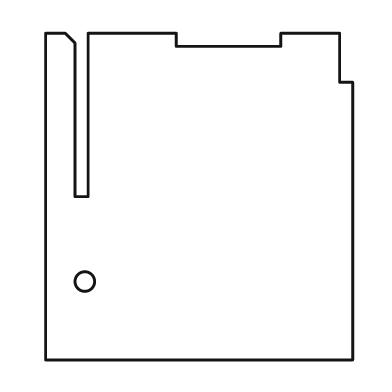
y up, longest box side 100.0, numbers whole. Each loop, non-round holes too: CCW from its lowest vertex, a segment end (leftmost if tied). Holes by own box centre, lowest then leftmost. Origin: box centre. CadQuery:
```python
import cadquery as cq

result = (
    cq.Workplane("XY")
    .moveTo(-47.0, -50.0)
    .lineTo(47.0, -50.0)
    .lineTo(47.0, 35.0)
    .lineTo(43.0, 35.0)
    .lineTo(43.0, 50.0)
    .lineTo(25.0, 50.0)
    .lineTo(25.0, 46.0)
    .lineTo(-7.0, 46.0)
    .lineTo(-7.0, 50.0)
    .lineTo(-34.0, 50.0)
    .lineTo(-34.0, 0.0)
    .lineTo(-38.0, 0.0)
    .lineTo(-38.0, 47.0)
    .lineTo(-41.0, 50.0)
    .lineTo(-47.0, 50.0)
    .close()
    .moveTo(-35.0, -26.0)
    .circle(3.0)
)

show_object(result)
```